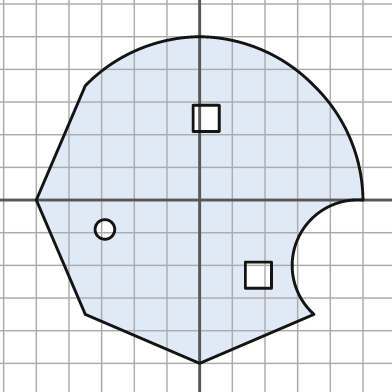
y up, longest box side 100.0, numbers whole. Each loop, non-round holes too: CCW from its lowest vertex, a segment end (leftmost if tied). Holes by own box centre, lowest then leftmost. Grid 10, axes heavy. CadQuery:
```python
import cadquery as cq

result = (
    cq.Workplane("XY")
    .moveTo(0.0, -50.0)
    .lineTo(35.0, -35.0)
    .threePointArc((30.0, -12.0), (50.0, 0.0))
    .threePointArc((46.0, 19.0), (35.0, 35.0))
    .threePointArc((19.0, 46.0), (0.0, 50.0))
    .threePointArc((-19.0, 46.0), (-35.0, 35.0))
    .lineTo(-50.0, 0.0)
    .lineTo(-35.0, -35.0)
    .close()
    .moveTo(14.0, -27.0)
    .lineTo(22.0, -27.0)
    .lineTo(22.0, -19.0)
    .lineTo(14.0, -19.0)
    .close()
    .moveTo(-29.0, -9.0)
    .circle(3.0)
    .moveTo(-2.0, 21.0)
    .lineTo(6.0, 21.0)
    .lineTo(6.0, 29.0)
    .lineTo(-2.0, 29.0)
    .close()
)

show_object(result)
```